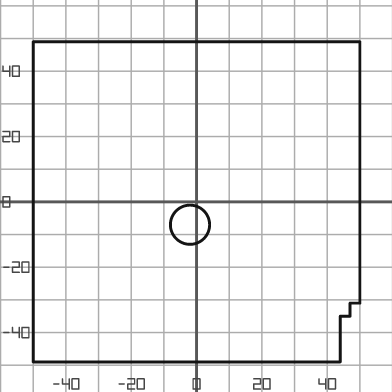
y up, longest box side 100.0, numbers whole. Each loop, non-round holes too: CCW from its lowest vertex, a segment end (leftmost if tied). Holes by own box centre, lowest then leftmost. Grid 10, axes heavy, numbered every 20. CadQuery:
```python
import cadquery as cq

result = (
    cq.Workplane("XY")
    .moveTo(-50.0, -49.0)
    .lineTo(44.0, -49.0)
    .lineTo(44.0, -35.0)
    .lineTo(47.0, -35.0)
    .lineTo(47.0, -31.0)
    .lineTo(50.0, -31.0)
    .lineTo(50.0, 49.0)
    .lineTo(-50.0, 49.0)
    .close()
    .moveTo(-2.0, -7.0)
    .circle(6.0)
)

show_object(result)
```